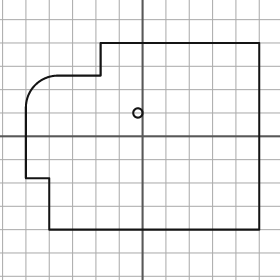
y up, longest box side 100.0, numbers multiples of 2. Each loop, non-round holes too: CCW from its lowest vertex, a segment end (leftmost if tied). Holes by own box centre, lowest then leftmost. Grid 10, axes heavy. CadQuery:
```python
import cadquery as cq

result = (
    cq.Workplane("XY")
    .moveTo(-40.0, -40.0)
    .lineTo(50.0, -40.0)
    .lineTo(50.0, 40.0)
    .lineTo(-18.0, 40.0)
    .lineTo(-18.0, 26.0)
    .lineTo(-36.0, 26.0)
    .threePointArc((-46.0, 22.0), (-50.0, 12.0))
    .lineTo(-50.0, -18.0)
    .lineTo(-40.0, -18.0)
    .close()
    .moveTo(-2.0, 10.0)
    .circle(2.0)
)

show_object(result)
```